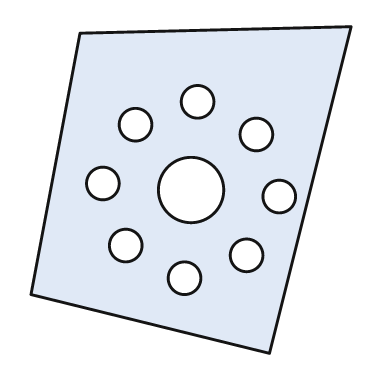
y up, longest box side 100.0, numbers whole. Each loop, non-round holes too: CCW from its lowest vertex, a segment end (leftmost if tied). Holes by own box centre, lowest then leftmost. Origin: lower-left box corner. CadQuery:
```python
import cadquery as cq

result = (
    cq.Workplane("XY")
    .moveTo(73.0, 0.0)
    .lineTo(98.0, 100.0)
    .lineTo(15.0, 98.0)
    .lineTo(0.0, 18.0)
    .close()
    .moveTo(47.0, 23.0)
    .circle(5.0)
    .moveTo(66.0, 30.0)
    .circle(5.0)
    .moveTo(29.0, 33.0)
    .circle(5.0)
    .moveTo(76.0, 48.0)
    .circle(5.0)
    .moveTo(49.0, 50.0)
    .circle(10.0)
    .moveTo(22.0, 52.0)
    .circle(5.0)
    .moveTo(69.0, 67.0)
    .circle(5.0)
    .moveTo(32.0, 70.0)
    .circle(5.0)
    .moveTo(51.0, 77.0)
    .circle(5.0)
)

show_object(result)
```